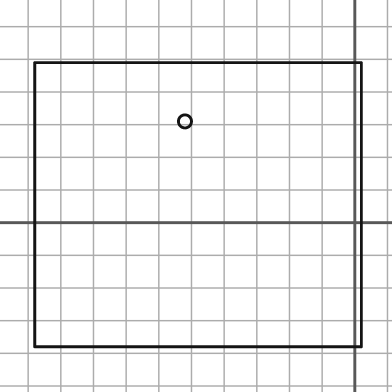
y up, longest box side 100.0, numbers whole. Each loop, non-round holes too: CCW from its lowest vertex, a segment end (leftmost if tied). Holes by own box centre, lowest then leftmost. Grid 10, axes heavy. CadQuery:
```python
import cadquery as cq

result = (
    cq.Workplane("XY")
    .moveTo(-98.0, -38.0)
    .lineTo(2.0, -38.0)
    .lineTo(2.0, 49.0)
    .lineTo(-98.0, 49.0)
    .close()
    .moveTo(-52.0, 31.0)
    .circle(2.0)
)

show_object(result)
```